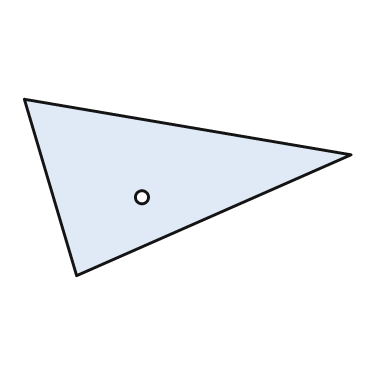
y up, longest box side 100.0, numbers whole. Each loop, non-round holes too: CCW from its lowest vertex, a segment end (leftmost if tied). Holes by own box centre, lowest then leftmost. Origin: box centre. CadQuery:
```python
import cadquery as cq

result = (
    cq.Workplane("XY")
    .moveTo(-34.0, -27.0)
    .lineTo(50.0, 10.0)
    .lineTo(-50.0, 27.0)
    .close()
    .moveTo(-14.0, -3.0)
    .circle(2.0)
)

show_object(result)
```